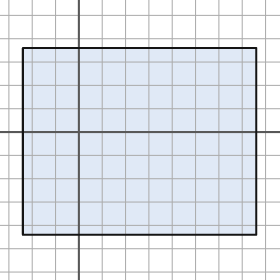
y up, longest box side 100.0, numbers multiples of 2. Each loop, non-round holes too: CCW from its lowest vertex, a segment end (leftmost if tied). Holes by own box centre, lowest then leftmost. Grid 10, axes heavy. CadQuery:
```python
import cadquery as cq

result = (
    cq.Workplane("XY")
    .moveTo(-24.0, -44.0)
    .lineTo(76.0, -44.0)
    .lineTo(76.0, 36.0)
    .lineTo(-24.0, 36.0)
    .close()
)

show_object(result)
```